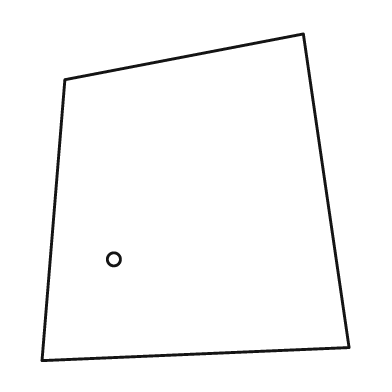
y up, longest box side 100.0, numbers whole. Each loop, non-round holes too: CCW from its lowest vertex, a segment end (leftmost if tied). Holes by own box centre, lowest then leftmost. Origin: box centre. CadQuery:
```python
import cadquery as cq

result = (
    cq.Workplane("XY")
    .moveTo(-47.0, -50.0)
    .lineTo(47.0, -46.0)
    .lineTo(33.0, 50.0)
    .lineTo(-40.0, 36.0)
    .close()
    .moveTo(-25.0, -19.0)
    .circle(2.0)
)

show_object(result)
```